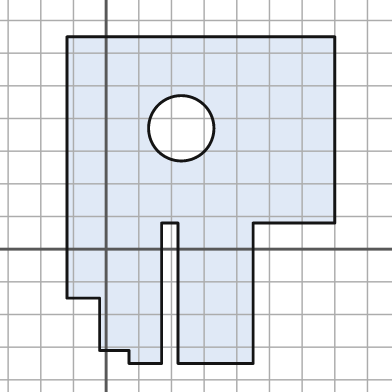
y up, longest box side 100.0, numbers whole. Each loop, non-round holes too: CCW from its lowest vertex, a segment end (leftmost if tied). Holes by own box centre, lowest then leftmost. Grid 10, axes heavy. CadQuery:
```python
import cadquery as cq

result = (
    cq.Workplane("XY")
    .moveTo(7.0, -35.0)
    .lineTo(17.0, -35.0)
    .lineTo(17.0, 8.0)
    .lineTo(22.0, 8.0)
    .lineTo(22.0, -35.0)
    .lineTo(45.0, -35.0)
    .lineTo(45.0, 8.0)
    .lineTo(70.0, 8.0)
    .lineTo(70.0, 65.0)
    .lineTo(-12.0, 65.0)
    .lineTo(-12.0, -15.0)
    .lineTo(-2.0, -15.0)
    .lineTo(-2.0, -31.0)
    .lineTo(7.0, -31.0)
    .close()
    .moveTo(23.0, 37.0)
    .circle(10.0)
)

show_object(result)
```